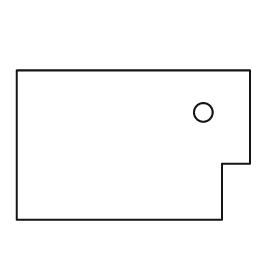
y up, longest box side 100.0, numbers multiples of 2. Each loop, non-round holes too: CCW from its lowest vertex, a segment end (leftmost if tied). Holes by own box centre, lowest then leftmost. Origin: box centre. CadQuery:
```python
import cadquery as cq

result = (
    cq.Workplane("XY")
    .moveTo(-50.0, -32.0)
    .lineTo(38.0, -32.0)
    .lineTo(38.0, -8.0)
    .lineTo(50.0, -8.0)
    .lineTo(50.0, 32.0)
    .lineTo(-50.0, 32.0)
    .close()
    .moveTo(30.0, 14.0)
    .circle(4.0)
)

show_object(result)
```